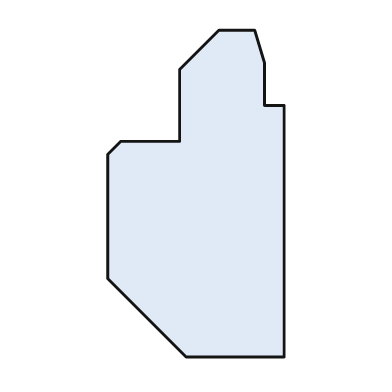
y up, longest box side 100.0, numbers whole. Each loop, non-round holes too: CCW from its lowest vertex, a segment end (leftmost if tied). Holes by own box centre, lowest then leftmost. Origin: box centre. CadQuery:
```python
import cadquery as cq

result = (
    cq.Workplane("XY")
    .moveTo(-3.0, -50.0)
    .lineTo(27.0, -50.0)
    .lineTo(27.0, 27.0)
    .lineTo(21.0, 27.0)
    .lineTo(21.0, 40.0)
    .lineTo(18.0, 50.0)
    .lineTo(7.0, 50.0)
    .lineTo(-5.0, 38.0)
    .lineTo(-5.0, 16.0)
    .lineTo(-23.0, 16.0)
    .lineTo(-27.0, 12.0)
    .lineTo(-27.0, -26.0)
    .close()
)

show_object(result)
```